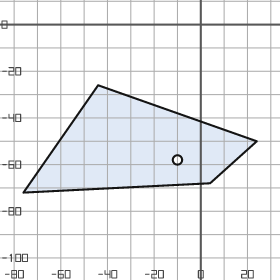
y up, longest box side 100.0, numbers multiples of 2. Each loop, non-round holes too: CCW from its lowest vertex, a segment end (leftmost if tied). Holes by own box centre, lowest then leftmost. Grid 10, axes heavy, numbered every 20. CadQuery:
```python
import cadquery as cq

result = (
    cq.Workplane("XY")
    .moveTo(-76.0, -72.0)
    .lineTo(4.0, -68.0)
    .lineTo(24.0, -50.0)
    .lineTo(-44.0, -26.0)
    .close()
    .moveTo(-10.0, -58.0)
    .circle(2.0)
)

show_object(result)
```